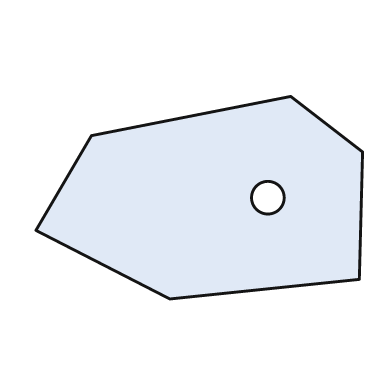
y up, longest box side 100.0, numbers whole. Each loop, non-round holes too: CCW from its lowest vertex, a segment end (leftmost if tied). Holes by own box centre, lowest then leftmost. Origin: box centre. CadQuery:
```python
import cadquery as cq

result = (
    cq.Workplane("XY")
    .moveTo(-9.0, -31.0)
    .lineTo(49.0, -25.0)
    .lineTo(50.0, 14.0)
    .lineTo(28.0, 31.0)
    .lineTo(-33.0, 19.0)
    .lineTo(-50.0, -10.0)
    .close()
    .moveTo(21.0, 0.0)
    .circle(5.0)
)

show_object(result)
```